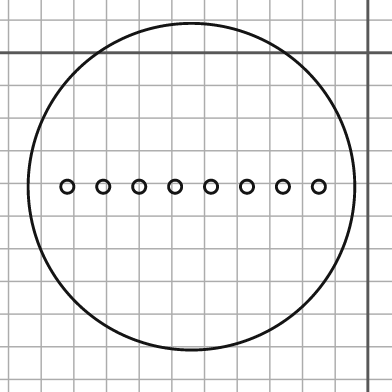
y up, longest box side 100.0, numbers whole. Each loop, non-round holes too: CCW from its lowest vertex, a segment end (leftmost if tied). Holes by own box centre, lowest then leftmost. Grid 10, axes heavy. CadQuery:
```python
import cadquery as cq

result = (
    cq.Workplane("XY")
    .moveTo(-54.0, -41.0)
    .circle(50.0)
    .moveTo(-92.0, -41.0)
    .circle(2.0)
    .moveTo(-81.0, -41.0)
    .circle(2.0)
    .moveTo(-70.0, -41.0)
    .circle(2.0)
    .moveTo(-59.0, -41.0)
    .circle(2.0)
    .moveTo(-48.0, -41.0)
    .circle(2.0)
    .moveTo(-37.0, -41.0)
    .circle(2.0)
    .moveTo(-26.0, -41.0)
    .circle(2.0)
    .moveTo(-15.0, -41.0)
    .circle(2.0)
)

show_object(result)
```